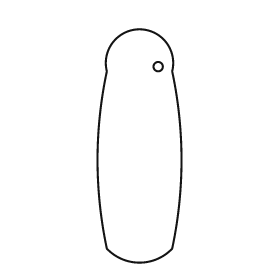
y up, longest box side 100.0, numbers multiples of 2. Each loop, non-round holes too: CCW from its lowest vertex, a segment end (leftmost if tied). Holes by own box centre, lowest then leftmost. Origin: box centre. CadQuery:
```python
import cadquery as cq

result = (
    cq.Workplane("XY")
    .moveTo(-14.0, -44.0)
    .threePointArc((0.0, -50.0), (14.0, -44.0))
    .threePointArc((18.0, -6.0), (14.0, 32.0))
    .threePointArc((0.0, 50.0), (-14.0, 32.0))
    .threePointArc((-18.0, -6.0), (-14.0, -44.0))
    .close()
    .moveTo(8.0, 34.0)
    .circle(2.0)
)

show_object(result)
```